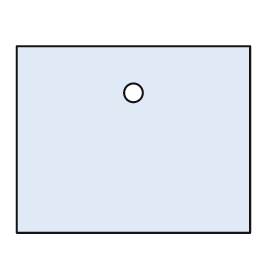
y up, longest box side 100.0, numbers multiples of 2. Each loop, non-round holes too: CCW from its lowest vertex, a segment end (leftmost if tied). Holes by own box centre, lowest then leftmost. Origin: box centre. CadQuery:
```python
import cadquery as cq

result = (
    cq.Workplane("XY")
    .moveTo(-50.0, -40.0)
    .lineTo(50.0, -40.0)
    .lineTo(50.0, 40.0)
    .lineTo(-50.0, 40.0)
    .close()
    .moveTo(0.0, 20.0)
    .circle(4.0)
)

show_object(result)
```